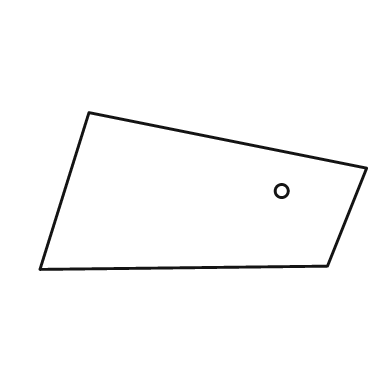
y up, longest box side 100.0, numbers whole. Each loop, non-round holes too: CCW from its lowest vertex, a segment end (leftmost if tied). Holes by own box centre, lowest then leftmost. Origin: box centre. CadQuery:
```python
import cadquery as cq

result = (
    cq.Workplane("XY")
    .moveTo(-50.0, -24.0)
    .lineTo(38.0, -23.0)
    .lineTo(50.0, 7.0)
    .lineTo(-35.0, 24.0)
    .close()
    .moveTo(24.0, 0.0)
    .circle(2.0)
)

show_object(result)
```